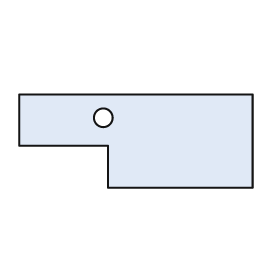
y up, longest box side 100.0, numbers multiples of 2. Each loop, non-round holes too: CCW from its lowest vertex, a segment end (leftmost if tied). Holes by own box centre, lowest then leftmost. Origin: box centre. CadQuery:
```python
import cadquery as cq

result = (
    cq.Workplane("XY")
    .moveTo(-12.0, -20.0)
    .lineTo(50.0, -20.0)
    .lineTo(50.0, 20.0)
    .lineTo(-50.0, 20.0)
    .lineTo(-50.0, -2.0)
    .lineTo(-12.0, -2.0)
    .close()
    .moveTo(-14.0, 10.0)
    .circle(4.0)
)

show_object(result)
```